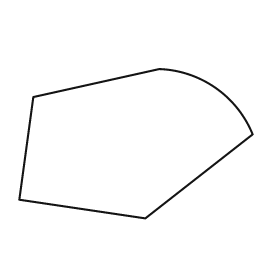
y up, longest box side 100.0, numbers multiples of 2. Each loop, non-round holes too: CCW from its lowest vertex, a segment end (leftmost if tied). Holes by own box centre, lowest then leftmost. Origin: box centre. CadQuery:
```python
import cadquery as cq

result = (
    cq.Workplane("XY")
    .moveTo(4.0, -32.0)
    .lineTo(50.0, 4.0)
    .threePointArc((34.0, 24.0), (10.0, 32.0))
    .lineTo(-44.0, 20.0)
    .lineTo(-50.0, -24.0)
    .close()
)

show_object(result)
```